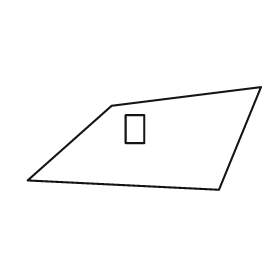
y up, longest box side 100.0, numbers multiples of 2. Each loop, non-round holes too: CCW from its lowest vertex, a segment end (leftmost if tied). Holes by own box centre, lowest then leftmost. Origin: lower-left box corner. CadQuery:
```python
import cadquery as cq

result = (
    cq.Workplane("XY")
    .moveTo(82.0, 0.0)
    .lineTo(100.0, 44.0)
    .lineTo(36.0, 36.0)
    .lineTo(0.0, 4.0)
    .close()
    .moveTo(42.0, 20.0)
    .lineTo(50.0, 20.0)
    .lineTo(50.0, 32.0)
    .lineTo(42.0, 32.0)
    .close()
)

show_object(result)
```